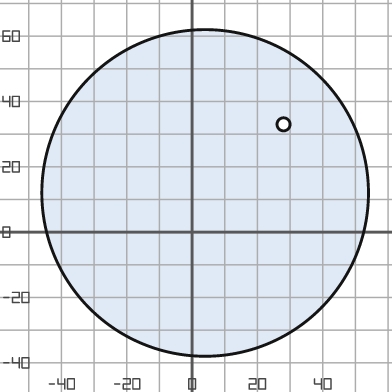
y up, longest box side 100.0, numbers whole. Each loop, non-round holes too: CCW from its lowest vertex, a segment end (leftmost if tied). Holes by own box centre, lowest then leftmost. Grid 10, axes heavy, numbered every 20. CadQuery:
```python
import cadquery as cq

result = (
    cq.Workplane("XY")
    .moveTo(4.0, 12.0)
    .circle(50.0)
    .moveTo(28.0, 33.0)
    .circle(2.0)
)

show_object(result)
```